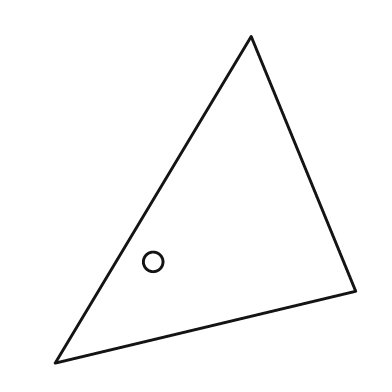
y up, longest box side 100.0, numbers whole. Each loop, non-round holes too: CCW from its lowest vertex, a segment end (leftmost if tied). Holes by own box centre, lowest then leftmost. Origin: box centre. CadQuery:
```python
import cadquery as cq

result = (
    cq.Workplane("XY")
    .moveTo(-46.0, -50.0)
    .lineTo(46.0, -28.0)
    .lineTo(14.0, 50.0)
    .close()
    .moveTo(-16.0, -19.0)
    .circle(3.0)
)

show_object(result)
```